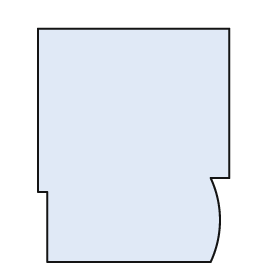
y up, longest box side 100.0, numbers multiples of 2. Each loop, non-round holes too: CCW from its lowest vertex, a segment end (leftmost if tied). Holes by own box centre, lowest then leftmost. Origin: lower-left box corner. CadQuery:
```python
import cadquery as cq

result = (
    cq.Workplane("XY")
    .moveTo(4.0, 0.0)
    .lineTo(74.0, 0.0)
    .threePointArc((78.0, 18.0), (74.0, 36.0))
    .lineTo(82.0, 36.0)
    .lineTo(82.0, 100.0)
    .lineTo(0.0, 100.0)
    .lineTo(0.0, 30.0)
    .lineTo(4.0, 30.0)
    .close()
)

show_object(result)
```